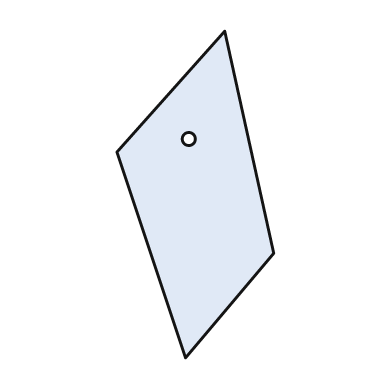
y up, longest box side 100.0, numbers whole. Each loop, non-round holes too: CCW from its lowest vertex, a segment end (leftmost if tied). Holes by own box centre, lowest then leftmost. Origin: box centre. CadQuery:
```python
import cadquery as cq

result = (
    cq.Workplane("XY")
    .moveTo(-3.0, -50.0)
    .lineTo(24.0, -18.0)
    .lineTo(9.0, 50.0)
    .lineTo(-24.0, 13.0)
    .close()
    .moveTo(-2.0, 17.0)
    .circle(2.0)
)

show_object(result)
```